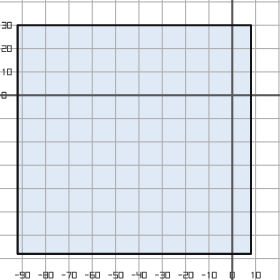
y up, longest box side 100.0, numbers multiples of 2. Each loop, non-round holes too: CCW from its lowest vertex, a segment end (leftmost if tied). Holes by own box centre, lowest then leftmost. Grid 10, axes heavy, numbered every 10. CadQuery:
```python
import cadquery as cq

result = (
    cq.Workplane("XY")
    .moveTo(-92.0, -68.0)
    .lineTo(8.0, -68.0)
    .lineTo(8.0, 30.0)
    .lineTo(-92.0, 30.0)
    .close()
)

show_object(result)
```